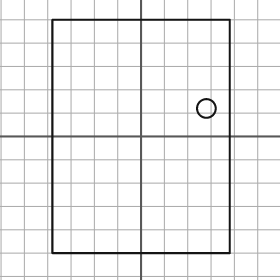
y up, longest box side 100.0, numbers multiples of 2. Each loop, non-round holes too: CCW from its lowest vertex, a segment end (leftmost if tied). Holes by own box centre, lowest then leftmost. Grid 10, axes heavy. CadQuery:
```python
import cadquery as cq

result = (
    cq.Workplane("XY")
    .moveTo(-38.0, -50.0)
    .lineTo(38.0, -50.0)
    .lineTo(38.0, 50.0)
    .lineTo(-38.0, 50.0)
    .close()
    .moveTo(28.0, 12.0)
    .circle(4.0)
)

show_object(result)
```